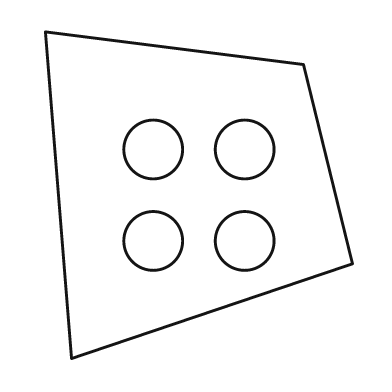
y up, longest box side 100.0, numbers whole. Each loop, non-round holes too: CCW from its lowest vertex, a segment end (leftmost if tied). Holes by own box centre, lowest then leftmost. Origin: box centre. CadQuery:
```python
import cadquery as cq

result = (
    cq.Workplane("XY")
    .moveTo(-39.0, -50.0)
    .lineTo(47.0, -21.0)
    .lineTo(32.0, 40.0)
    .lineTo(-47.0, 50.0)
    .close()
    .moveTo(-14.0, -14.0)
    .circle(9.0)
    .moveTo(14.0, -14.0)
    .circle(9.0)
    .moveTo(-14.0, 14.0)
    .circle(9.0)
    .moveTo(14.0, 14.0)
    .circle(9.0)
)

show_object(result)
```